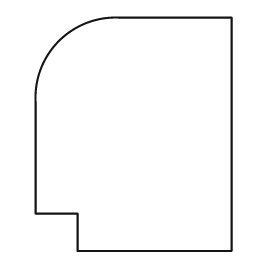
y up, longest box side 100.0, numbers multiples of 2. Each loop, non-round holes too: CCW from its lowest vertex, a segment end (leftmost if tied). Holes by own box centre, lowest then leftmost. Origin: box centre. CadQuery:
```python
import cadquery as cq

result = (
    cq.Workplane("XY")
    .moveTo(-24.0, -50.0)
    .lineTo(42.0, -50.0)
    .lineTo(42.0, 50.0)
    .lineTo(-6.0, 50.0)
    .threePointArc((-32.0, 40.0), (-42.0, 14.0))
    .lineTo(-42.0, -34.0)
    .lineTo(-24.0, -34.0)
    .close()
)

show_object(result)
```